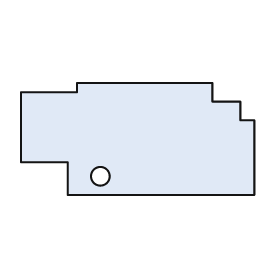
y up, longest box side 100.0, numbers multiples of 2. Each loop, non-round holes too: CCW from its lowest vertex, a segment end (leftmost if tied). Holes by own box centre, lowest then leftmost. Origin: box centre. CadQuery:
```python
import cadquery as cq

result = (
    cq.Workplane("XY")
    .moveTo(-30.0, -24.0)
    .lineTo(50.0, -24.0)
    .lineTo(50.0, 8.0)
    .lineTo(44.0, 8.0)
    .lineTo(44.0, 16.0)
    .lineTo(32.0, 16.0)
    .lineTo(32.0, 24.0)
    .lineTo(-26.0, 24.0)
    .lineTo(-26.0, 20.0)
    .lineTo(-50.0, 20.0)
    .lineTo(-50.0, -10.0)
    .lineTo(-30.0, -10.0)
    .close()
    .moveTo(-16.0, -16.0)
    .circle(4.0)
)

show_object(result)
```